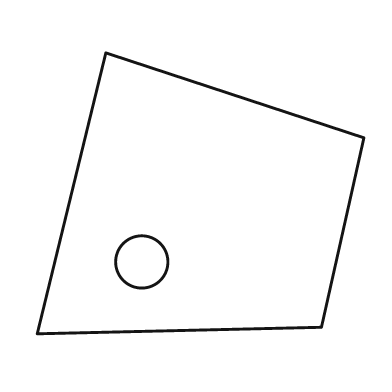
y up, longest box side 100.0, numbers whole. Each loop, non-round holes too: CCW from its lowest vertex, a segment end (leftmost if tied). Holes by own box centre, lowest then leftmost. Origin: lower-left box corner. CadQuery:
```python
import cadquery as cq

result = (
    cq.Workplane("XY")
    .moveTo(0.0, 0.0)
    .lineTo(87.0, 2.0)
    .lineTo(100.0, 60.0)
    .lineTo(21.0, 86.0)
    .close()
    .moveTo(32.0, 22.0)
    .circle(8.0)
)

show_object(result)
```